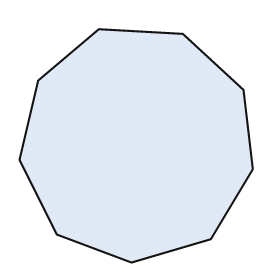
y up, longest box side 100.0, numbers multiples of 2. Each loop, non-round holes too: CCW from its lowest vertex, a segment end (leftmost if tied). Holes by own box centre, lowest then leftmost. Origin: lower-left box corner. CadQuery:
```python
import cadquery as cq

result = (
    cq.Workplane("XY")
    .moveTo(48.0, 0.0)
    .lineTo(82.0, 10.0)
    .lineTo(100.0, 40.0)
    .lineTo(96.0, 74.0)
    .lineTo(70.0, 98.0)
    .lineTo(34.0, 100.0)
    .lineTo(8.0, 78.0)
    .lineTo(0.0, 44.0)
    .lineTo(16.0, 12.0)
    .close()
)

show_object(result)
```